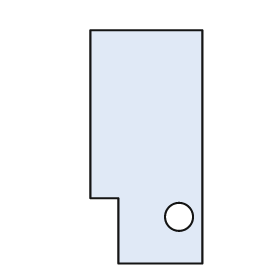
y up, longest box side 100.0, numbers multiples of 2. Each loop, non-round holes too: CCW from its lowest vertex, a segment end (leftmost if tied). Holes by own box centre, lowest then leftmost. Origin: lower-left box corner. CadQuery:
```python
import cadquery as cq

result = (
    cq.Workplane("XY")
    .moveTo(12.0, 0.0)
    .lineTo(48.0, 0.0)
    .lineTo(48.0, 100.0)
    .lineTo(0.0, 100.0)
    .lineTo(0.0, 28.0)
    .lineTo(12.0, 28.0)
    .close()
    .moveTo(38.0, 20.0)
    .circle(6.0)
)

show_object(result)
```